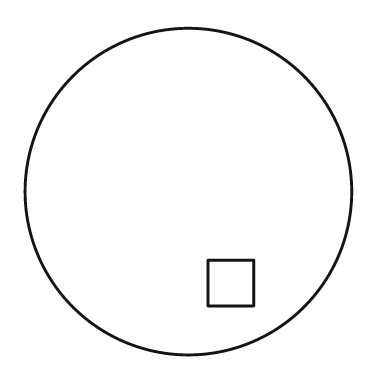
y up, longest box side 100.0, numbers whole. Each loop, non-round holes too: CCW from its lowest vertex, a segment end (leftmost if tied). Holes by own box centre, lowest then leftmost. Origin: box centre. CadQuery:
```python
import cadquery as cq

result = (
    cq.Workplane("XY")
    .moveTo(0.0, 0.0)
    .circle(50.0)
    .moveTo(6.0, -35.0)
    .lineTo(20.0, -35.0)
    .lineTo(20.0, -21.0)
    .lineTo(6.0, -21.0)
    .close()
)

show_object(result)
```